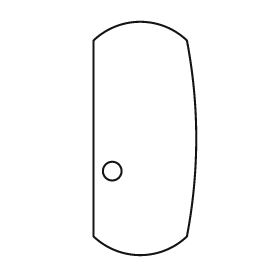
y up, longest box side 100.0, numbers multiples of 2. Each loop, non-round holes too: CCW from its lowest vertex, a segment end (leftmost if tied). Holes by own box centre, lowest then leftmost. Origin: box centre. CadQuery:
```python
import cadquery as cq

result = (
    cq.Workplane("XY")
    .moveTo(-22.0, -42.0)
    .threePointArc((-2.0, -50.0), (18.0, -42.0))
    .threePointArc((22.0, 0.0), (18.0, 42.0))
    .threePointArc((-2.0, 50.0), (-22.0, 42.0))
    .close()
    .moveTo(-14.0, -14.0)
    .circle(4.0)
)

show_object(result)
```